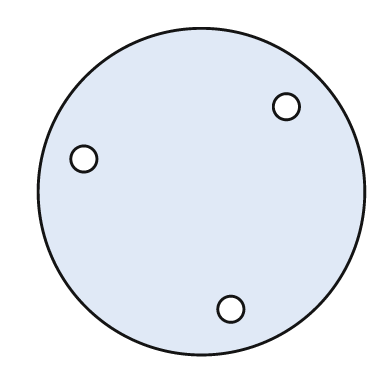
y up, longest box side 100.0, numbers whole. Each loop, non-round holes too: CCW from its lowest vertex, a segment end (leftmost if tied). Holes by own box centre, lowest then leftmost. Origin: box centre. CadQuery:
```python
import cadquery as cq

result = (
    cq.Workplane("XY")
    .moveTo(0.0, 0.0)
    .circle(50.0)
    .moveTo(9.0, -36.0)
    .circle(4.0)
    .moveTo(-36.0, 10.0)
    .circle(4.0)
    .moveTo(26.0, 26.0)
    .circle(4.0)
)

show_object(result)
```